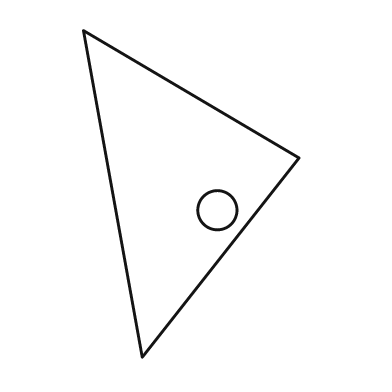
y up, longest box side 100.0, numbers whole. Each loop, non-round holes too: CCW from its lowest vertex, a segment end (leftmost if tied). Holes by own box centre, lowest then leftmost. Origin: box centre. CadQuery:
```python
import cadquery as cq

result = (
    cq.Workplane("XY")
    .moveTo(-15.0, -50.0)
    .lineTo(33.0, 11.0)
    .lineTo(-33.0, 50.0)
    .close()
    .moveTo(8.0, -5.0)
    .circle(6.0)
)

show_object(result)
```